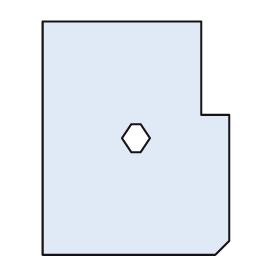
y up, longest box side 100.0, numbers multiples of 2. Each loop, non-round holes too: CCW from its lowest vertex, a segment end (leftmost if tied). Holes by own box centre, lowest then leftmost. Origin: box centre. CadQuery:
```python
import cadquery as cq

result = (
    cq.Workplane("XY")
    .moveTo(-40.0, -50.0)
    .lineTo(34.0, -50.0)
    .lineTo(40.0, -44.0)
    .lineTo(40.0, 10.0)
    .lineTo(28.0, 10.0)
    .lineTo(28.0, 50.0)
    .lineTo(-40.0, 50.0)
    .close()
    .moveTo(-2.0, -6.0)
    .lineTo(2.0, -6.0)
    .lineTo(6.0, 0.0)
    .lineTo(2.0, 6.0)
    .lineTo(-2.0, 6.0)
    .lineTo(-6.0, 0.0)
    .close()
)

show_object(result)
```